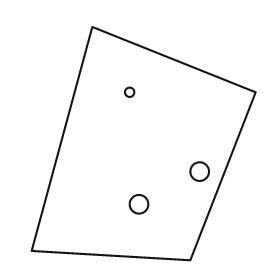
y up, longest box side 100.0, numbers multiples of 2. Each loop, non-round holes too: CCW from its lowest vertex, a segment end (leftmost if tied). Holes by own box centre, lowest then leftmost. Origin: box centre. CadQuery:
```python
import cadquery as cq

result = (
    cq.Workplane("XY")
    .moveTo(20.0, -50.0)
    .lineTo(48.0, 22.0)
    .lineTo(-22.0, 50.0)
    .lineTo(-48.0, -46.0)
    .close()
    .moveTo(-2.0, -26.0)
    .circle(4.0)
    .moveTo(24.0, -12.0)
    .circle(4.0)
    .moveTo(-6.0, 22.0)
    .circle(2.0)
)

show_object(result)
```